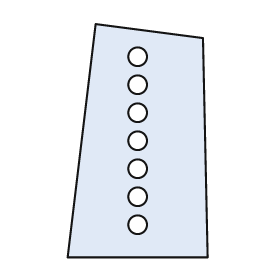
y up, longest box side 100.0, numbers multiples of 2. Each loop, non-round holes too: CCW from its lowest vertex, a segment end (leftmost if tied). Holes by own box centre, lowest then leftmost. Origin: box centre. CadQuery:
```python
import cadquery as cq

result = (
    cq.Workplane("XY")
    .moveTo(-30.0, -50.0)
    .lineTo(30.0, -50.0)
    .lineTo(28.0, 44.0)
    .lineTo(-18.0, 50.0)
    .close()
    .moveTo(0.0, -36.0)
    .circle(4.0)
    .moveTo(0.0, -24.0)
    .circle(4.0)
    .moveTo(0.0, -12.0)
    .circle(4.0)
    .moveTo(0.0, 0.0)
    .circle(4.0)
    .moveTo(0.0, 12.0)
    .circle(4.0)
    .moveTo(0.0, 24.0)
    .circle(4.0)
    .moveTo(0.0, 36.0)
    .circle(4.0)
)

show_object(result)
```